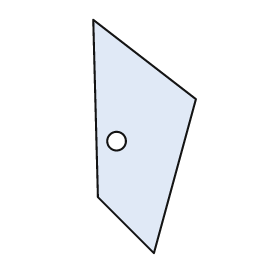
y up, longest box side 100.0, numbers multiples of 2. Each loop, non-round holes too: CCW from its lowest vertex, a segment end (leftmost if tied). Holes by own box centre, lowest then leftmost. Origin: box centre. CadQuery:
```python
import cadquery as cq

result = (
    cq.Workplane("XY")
    .moveTo(4.0, -50.0)
    .lineTo(22.0, 16.0)
    .lineTo(-22.0, 50.0)
    .lineTo(-20.0, -26.0)
    .close()
    .moveTo(-12.0, -2.0)
    .circle(4.0)
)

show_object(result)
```